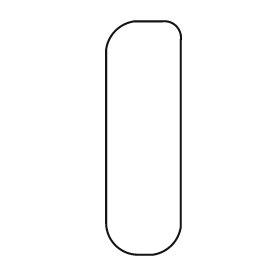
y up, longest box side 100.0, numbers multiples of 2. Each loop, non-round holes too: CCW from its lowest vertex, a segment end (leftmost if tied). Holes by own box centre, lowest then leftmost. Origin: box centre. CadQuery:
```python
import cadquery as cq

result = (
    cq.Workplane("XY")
    .moveTo(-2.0, -50.0)
    .lineTo(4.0, -50.0)
    .threePointArc((12.0, -46.0), (16.0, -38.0))
    .lineTo(16.0, 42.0)
    .threePointArc((14.0, 48.0), (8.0, 50.0))
    .lineTo(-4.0, 50.0)
    .threePointArc((-12.0, 46.0), (-16.0, 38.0))
    .lineTo(-16.0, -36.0)
    .threePointArc((-12.0, -46.0), (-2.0, -50.0))
    .close()
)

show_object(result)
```